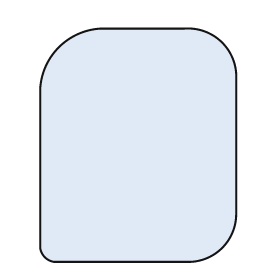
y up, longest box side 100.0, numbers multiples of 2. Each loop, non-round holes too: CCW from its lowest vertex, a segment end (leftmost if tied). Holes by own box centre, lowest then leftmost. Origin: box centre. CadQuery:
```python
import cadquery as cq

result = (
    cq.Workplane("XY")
    .moveTo(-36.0, -50.0)
    .lineTo(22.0, -50.0)
    .threePointArc((36.0, -44.0), (42.0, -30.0))
    .lineTo(42.0, 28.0)
    .threePointArc((36.0, 44.0), (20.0, 50.0))
    .lineTo(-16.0, 50.0)
    .threePointArc((-34.0, 42.0), (-42.0, 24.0))
    .lineTo(-42.0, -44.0)
    .threePointArc((-40.0, -48.0), (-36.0, -50.0))
    .close()
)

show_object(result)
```